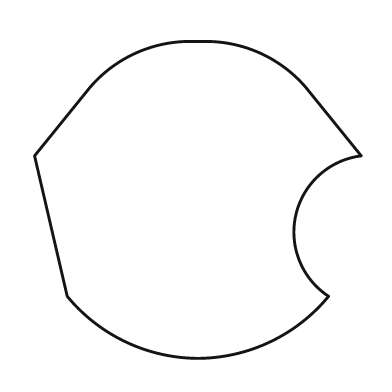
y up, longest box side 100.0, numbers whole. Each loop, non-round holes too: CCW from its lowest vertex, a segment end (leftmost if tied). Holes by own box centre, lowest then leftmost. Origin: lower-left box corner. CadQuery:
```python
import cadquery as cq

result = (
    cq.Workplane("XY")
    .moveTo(50.0, 0.0)
    .threePointArc((72.0, 5.0), (90.0, 19.0))
    .threePointArc((80.0, 44.0), (100.0, 62.0))
    .lineTo(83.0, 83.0)
    .threePointArc((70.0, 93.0), (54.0, 97.0))
    .lineTo(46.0, 97.0)
    .threePointArc((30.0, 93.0), (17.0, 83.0))
    .lineTo(0.0, 62.0)
    .lineTo(10.0, 19.0)
    .threePointArc((28.0, 5.0), (50.0, 0.0))
    .close()
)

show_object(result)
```